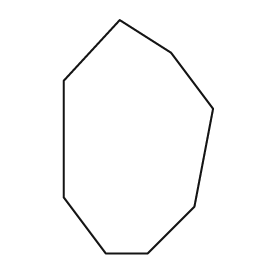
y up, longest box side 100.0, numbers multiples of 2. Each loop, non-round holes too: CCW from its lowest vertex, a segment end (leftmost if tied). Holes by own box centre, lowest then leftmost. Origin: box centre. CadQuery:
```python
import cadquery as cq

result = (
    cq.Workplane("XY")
    .moveTo(-14.0, -50.0)
    .lineTo(4.0, -50.0)
    .lineTo(24.0, -30.0)
    .lineTo(32.0, 12.0)
    .lineTo(14.0, 36.0)
    .lineTo(-8.0, 50.0)
    .lineTo(-32.0, 24.0)
    .lineTo(-32.0, -26.0)
    .close()
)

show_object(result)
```